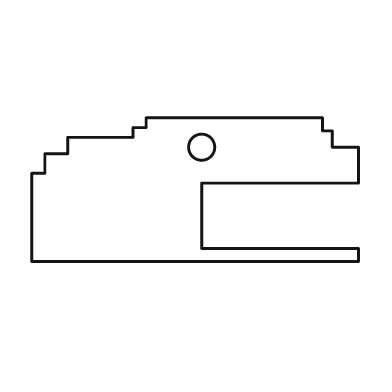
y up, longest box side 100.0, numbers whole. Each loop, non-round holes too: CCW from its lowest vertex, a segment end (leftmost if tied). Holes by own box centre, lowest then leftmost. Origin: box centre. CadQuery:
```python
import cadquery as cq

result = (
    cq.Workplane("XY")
    .moveTo(-50.0, -22.0)
    .lineTo(50.0, -22.0)
    .lineTo(50.0, -18.0)
    .lineTo(2.0, -18.0)
    .lineTo(2.0, 2.0)
    .lineTo(50.0, 2.0)
    .lineTo(50.0, 13.0)
    .lineTo(42.0, 13.0)
    .lineTo(42.0, 18.0)
    .lineTo(39.0, 18.0)
    .lineTo(39.0, 22.0)
    .lineTo(-15.0, 22.0)
    .lineTo(-15.0, 19.0)
    .lineTo(-19.0, 19.0)
    .lineTo(-19.0, 16.0)
    .lineTo(-39.0, 16.0)
    .lineTo(-39.0, 11.0)
    .lineTo(-46.0, 11.0)
    .lineTo(-46.0, 5.0)
    .lineTo(-50.0, 5.0)
    .close()
    .moveTo(2.0, 13.0)
    .circle(4.0)
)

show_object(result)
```